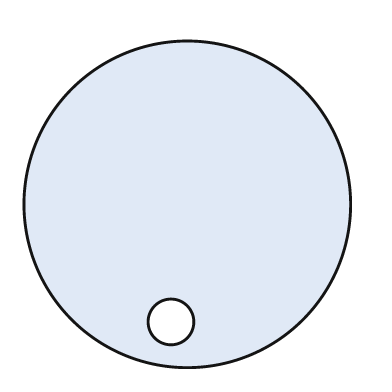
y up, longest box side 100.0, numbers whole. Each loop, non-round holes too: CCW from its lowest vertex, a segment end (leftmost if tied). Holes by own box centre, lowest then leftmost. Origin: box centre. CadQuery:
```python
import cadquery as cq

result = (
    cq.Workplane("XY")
    .moveTo(0.0, 0.0)
    .circle(50.0)
    .moveTo(-5.0, -36.0)
    .circle(7.0)
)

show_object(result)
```